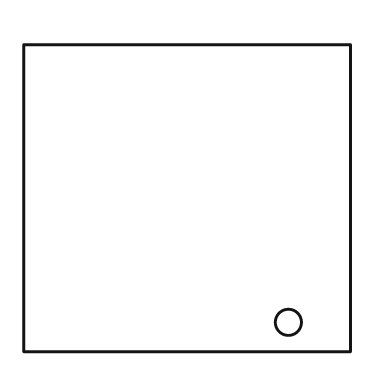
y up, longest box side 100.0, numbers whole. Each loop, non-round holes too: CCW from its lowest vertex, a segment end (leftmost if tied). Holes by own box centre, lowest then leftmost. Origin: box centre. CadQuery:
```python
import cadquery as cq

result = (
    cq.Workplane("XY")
    .moveTo(-50.0, -47.0)
    .lineTo(50.0, -47.0)
    .lineTo(50.0, 47.0)
    .lineTo(-50.0, 47.0)
    .close()
    .moveTo(31.0, -38.0)
    .circle(4.0)
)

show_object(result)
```